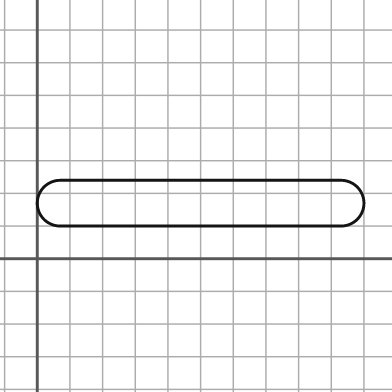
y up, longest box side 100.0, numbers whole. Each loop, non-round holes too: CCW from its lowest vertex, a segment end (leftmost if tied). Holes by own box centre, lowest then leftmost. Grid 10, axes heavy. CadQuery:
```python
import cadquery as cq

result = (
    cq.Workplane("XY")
    .moveTo(7.0, 10.0)
    .lineTo(93.0, 10.0)
    .threePointArc((100.0, 17.0), (93.0, 24.0))
    .lineTo(7.0, 24.0)
    .threePointArc((0.0, 17.0), (7.0, 10.0))
    .close()
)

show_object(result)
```